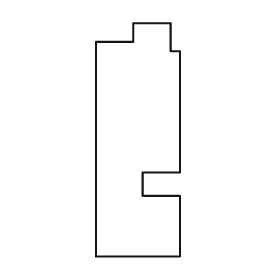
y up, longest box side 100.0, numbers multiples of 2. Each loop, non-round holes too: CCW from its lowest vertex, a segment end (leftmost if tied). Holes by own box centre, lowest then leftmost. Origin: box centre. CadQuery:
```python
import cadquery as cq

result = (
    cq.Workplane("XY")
    .moveTo(-18.0, -50.0)
    .lineTo(18.0, -50.0)
    .lineTo(18.0, -24.0)
    .lineTo(2.0, -24.0)
    .lineTo(2.0, -14.0)
    .lineTo(18.0, -14.0)
    .lineTo(18.0, 38.0)
    .lineTo(14.0, 38.0)
    .lineTo(14.0, 50.0)
    .lineTo(-2.0, 50.0)
    .lineTo(-2.0, 42.0)
    .lineTo(-18.0, 42.0)
    .close()
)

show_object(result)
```